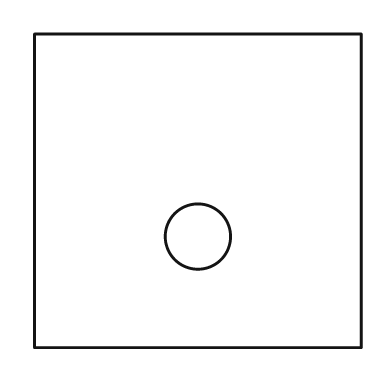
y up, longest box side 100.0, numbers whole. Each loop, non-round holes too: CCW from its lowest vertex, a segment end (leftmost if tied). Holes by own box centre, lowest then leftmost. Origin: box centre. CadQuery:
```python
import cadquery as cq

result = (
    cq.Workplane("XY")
    .moveTo(-50.0, -48.0)
    .lineTo(50.0, -48.0)
    .lineTo(50.0, 48.0)
    .lineTo(-50.0, 48.0)
    .close()
    .moveTo(0.0, -14.0)
    .circle(10.0)
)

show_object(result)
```